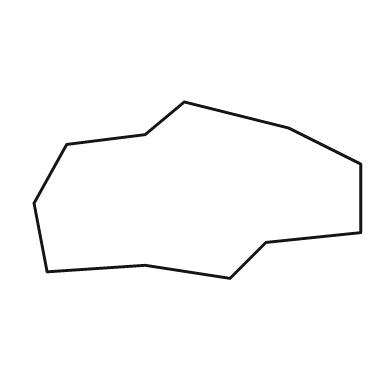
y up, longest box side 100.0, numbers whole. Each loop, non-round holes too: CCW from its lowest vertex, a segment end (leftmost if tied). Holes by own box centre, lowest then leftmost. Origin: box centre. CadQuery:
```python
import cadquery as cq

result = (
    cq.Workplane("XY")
    .moveTo(10.0, -27.0)
    .lineTo(21.0, -16.0)
    .lineTo(50.0, -13.0)
    .lineTo(50.0, 8.0)
    .lineTo(28.0, 19.0)
    .lineTo(-4.0, 27.0)
    .lineTo(-16.0, 17.0)
    .lineTo(-40.0, 14.0)
    .lineTo(-50.0, -4.0)
    .lineTo(-46.0, -25.0)
    .lineTo(-16.0, -23.0)
    .close()
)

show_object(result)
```